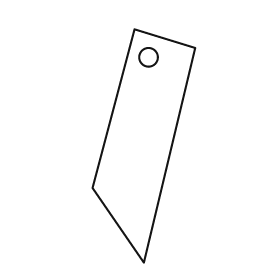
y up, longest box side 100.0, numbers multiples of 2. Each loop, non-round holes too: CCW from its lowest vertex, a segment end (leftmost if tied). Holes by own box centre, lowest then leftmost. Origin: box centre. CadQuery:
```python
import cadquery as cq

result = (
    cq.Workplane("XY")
    .moveTo(0.0, -50.0)
    .lineTo(22.0, 42.0)
    .lineTo(-4.0, 50.0)
    .lineTo(-22.0, -18.0)
    .close()
    .moveTo(2.0, 38.0)
    .circle(4.0)
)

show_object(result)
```